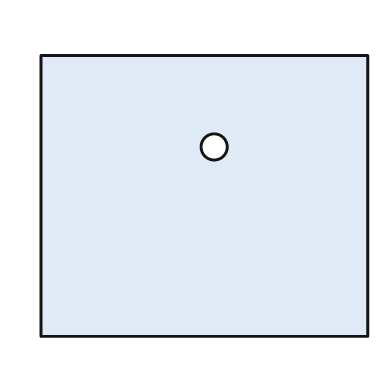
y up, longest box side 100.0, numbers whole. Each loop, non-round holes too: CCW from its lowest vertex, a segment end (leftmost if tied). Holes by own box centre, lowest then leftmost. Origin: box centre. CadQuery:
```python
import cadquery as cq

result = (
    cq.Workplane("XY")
    .moveTo(-50.0, -43.0)
    .lineTo(50.0, -43.0)
    .lineTo(50.0, 43.0)
    .lineTo(-50.0, 43.0)
    .close()
    .moveTo(3.0, 15.0)
    .circle(4.0)
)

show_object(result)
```